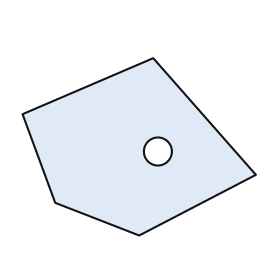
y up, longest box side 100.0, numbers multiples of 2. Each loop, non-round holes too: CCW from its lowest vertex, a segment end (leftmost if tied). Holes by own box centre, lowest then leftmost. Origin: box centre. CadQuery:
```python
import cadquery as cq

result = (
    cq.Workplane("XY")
    .moveTo(0.0, -38.0)
    .lineTo(50.0, -12.0)
    .lineTo(6.0, 38.0)
    .lineTo(-50.0, 14.0)
    .lineTo(-36.0, -24.0)
    .close()
    .moveTo(8.0, -2.0)
    .circle(6.0)
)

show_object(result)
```